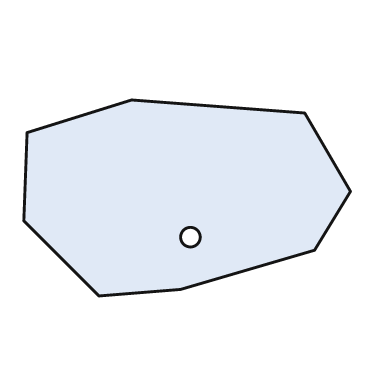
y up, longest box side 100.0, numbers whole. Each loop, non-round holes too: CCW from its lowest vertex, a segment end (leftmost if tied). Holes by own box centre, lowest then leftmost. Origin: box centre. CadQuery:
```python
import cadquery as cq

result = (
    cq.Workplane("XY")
    .moveTo(-27.0, -30.0)
    .lineTo(-2.0, -28.0)
    .lineTo(39.0, -16.0)
    .lineTo(50.0, 2.0)
    .lineTo(36.0, 26.0)
    .lineTo(-17.0, 30.0)
    .lineTo(-49.0, 20.0)
    .lineTo(-50.0, -7.0)
    .close()
    .moveTo(1.0, -12.0)
    .circle(3.0)
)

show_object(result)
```